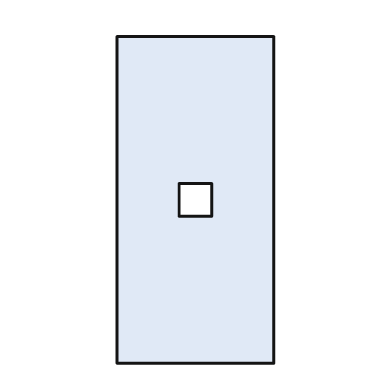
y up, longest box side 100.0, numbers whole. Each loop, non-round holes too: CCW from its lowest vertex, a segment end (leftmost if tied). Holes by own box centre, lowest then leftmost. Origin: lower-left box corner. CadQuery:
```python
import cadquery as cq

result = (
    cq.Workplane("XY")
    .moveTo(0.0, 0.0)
    .lineTo(48.0, 0.0)
    .lineTo(48.0, 100.0)
    .lineTo(0.0, 100.0)
    .close()
    .moveTo(19.0, 45.0)
    .lineTo(29.0, 45.0)
    .lineTo(29.0, 55.0)
    .lineTo(19.0, 55.0)
    .close()
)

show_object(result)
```